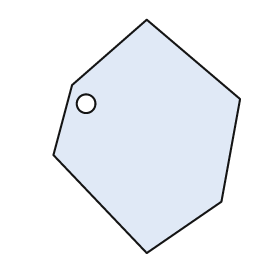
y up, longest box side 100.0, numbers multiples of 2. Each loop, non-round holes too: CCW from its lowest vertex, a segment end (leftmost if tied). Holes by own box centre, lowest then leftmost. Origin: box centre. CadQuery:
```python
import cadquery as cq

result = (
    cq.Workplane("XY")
    .moveTo(0.0, -50.0)
    .lineTo(32.0, -28.0)
    .lineTo(40.0, 16.0)
    .lineTo(0.0, 50.0)
    .lineTo(-32.0, 22.0)
    .lineTo(-40.0, -8.0)
    .close()
    .moveTo(-26.0, 14.0)
    .circle(4.0)
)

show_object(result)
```